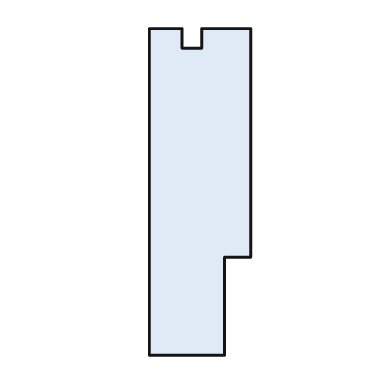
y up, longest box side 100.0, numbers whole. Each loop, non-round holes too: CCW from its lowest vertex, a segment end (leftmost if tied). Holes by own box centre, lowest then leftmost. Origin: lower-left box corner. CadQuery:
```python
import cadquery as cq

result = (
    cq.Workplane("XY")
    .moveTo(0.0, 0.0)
    .lineTo(23.0, 0.0)
    .lineTo(23.0, 30.0)
    .lineTo(31.0, 30.0)
    .lineTo(31.0, 100.0)
    .lineTo(16.0, 100.0)
    .lineTo(16.0, 94.0)
    .lineTo(10.0, 94.0)
    .lineTo(10.0, 100.0)
    .lineTo(0.0, 100.0)
    .close()
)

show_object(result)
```